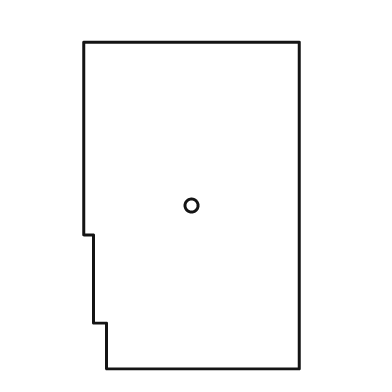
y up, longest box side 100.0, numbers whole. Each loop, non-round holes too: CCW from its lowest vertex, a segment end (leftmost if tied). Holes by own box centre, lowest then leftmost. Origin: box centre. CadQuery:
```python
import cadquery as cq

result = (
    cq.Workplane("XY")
    .moveTo(-26.0, -50.0)
    .lineTo(33.0, -50.0)
    .lineTo(33.0, 50.0)
    .lineTo(-33.0, 50.0)
    .lineTo(-33.0, -9.0)
    .lineTo(-30.0, -9.0)
    .lineTo(-30.0, -36.0)
    .lineTo(-26.0, -36.0)
    .close()
    .moveTo(0.0, 0.0)
    .circle(2.0)
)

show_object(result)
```